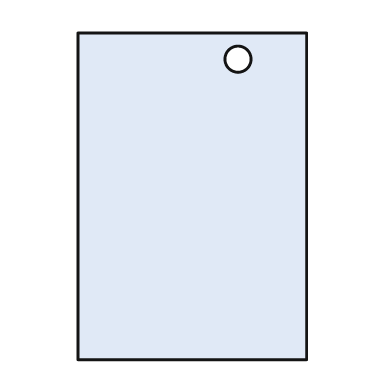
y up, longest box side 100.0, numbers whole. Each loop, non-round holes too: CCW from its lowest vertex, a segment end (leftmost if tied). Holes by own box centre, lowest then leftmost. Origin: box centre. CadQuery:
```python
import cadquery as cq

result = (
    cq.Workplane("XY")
    .moveTo(-35.0, -50.0)
    .lineTo(35.0, -50.0)
    .lineTo(35.0, 50.0)
    .lineTo(-35.0, 50.0)
    .close()
    .moveTo(14.0, 42.0)
    .circle(4.0)
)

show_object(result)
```